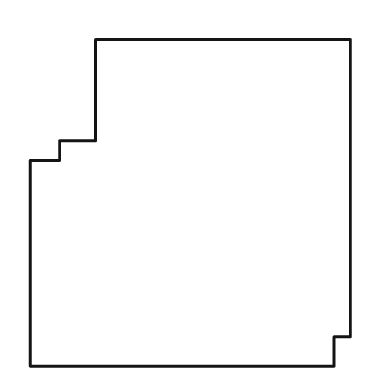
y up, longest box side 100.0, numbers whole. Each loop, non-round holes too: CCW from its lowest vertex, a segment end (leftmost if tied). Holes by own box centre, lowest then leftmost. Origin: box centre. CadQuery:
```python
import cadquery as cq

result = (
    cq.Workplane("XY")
    .moveTo(-49.0, -50.0)
    .lineTo(44.0, -50.0)
    .lineTo(44.0, -41.0)
    .lineTo(49.0, -41.0)
    .lineTo(49.0, 50.0)
    .lineTo(-29.0, 50.0)
    .lineTo(-29.0, 19.0)
    .lineTo(-40.0, 19.0)
    .lineTo(-40.0, 13.0)
    .lineTo(-49.0, 13.0)
    .close()
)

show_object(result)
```